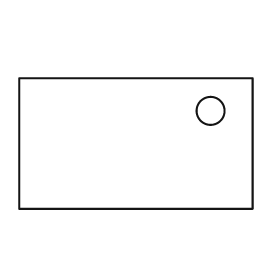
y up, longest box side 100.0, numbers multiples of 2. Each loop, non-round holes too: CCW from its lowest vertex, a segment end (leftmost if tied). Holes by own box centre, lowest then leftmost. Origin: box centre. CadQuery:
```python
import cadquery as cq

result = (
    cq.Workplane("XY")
    .moveTo(-50.0, -28.0)
    .lineTo(50.0, -28.0)
    .lineTo(50.0, 28.0)
    .lineTo(-50.0, 28.0)
    .close()
    .moveTo(32.0, 14.0)
    .circle(6.0)
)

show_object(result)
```